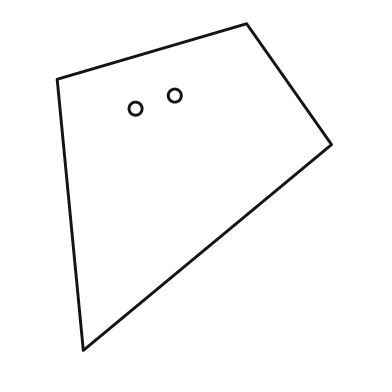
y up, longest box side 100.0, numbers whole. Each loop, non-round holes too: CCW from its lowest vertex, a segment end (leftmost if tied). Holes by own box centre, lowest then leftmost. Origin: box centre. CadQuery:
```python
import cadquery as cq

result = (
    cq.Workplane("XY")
    .moveTo(-34.0, -50.0)
    .lineTo(42.0, 13.0)
    .lineTo(16.0, 50.0)
    .lineTo(-42.0, 33.0)
    .close()
    .moveTo(-18.0, 24.0)
    .circle(2.0)
    .moveTo(-6.0, 28.0)
    .circle(2.0)
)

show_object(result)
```